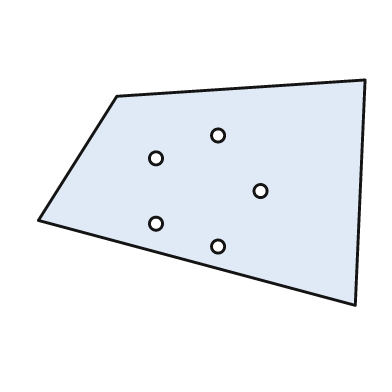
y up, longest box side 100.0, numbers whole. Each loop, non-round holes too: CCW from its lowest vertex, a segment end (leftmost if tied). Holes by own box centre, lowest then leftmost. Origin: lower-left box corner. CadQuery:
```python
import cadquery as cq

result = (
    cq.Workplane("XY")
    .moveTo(97.0, 0.0)
    .lineTo(100.0, 69.0)
    .lineTo(24.0, 64.0)
    .lineTo(0.0, 26.0)
    .close()
    .moveTo(55.0, 18.0)
    .circle(2.0)
    .moveTo(36.0, 25.0)
    .circle(2.0)
    .moveTo(68.0, 35.0)
    .circle(2.0)
    .moveTo(36.0, 45.0)
    .circle(2.0)
    .moveTo(55.0, 52.0)
    .circle(2.0)
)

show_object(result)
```